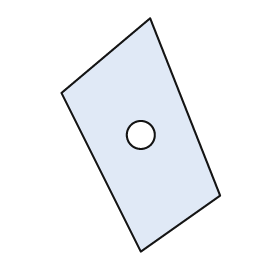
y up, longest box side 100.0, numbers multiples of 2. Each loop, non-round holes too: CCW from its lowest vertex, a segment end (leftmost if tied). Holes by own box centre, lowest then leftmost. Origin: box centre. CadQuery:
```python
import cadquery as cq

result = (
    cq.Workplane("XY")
    .moveTo(0.0, -50.0)
    .lineTo(34.0, -26.0)
    .lineTo(4.0, 50.0)
    .lineTo(-34.0, 18.0)
    .close()
    .moveTo(0.0, 0.0)
    .circle(6.0)
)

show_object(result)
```